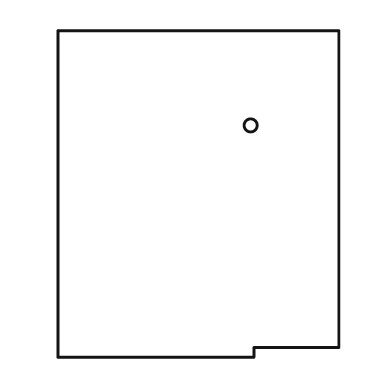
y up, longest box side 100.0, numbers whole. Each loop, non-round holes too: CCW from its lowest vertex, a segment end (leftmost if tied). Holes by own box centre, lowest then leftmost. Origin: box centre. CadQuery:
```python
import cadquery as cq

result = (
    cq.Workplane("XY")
    .moveTo(-43.0, -50.0)
    .lineTo(17.0, -50.0)
    .lineTo(17.0, -47.0)
    .lineTo(43.0, -47.0)
    .lineTo(43.0, 50.0)
    .lineTo(-43.0, 50.0)
    .close()
    .moveTo(16.0, 21.0)
    .circle(2.0)
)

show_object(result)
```